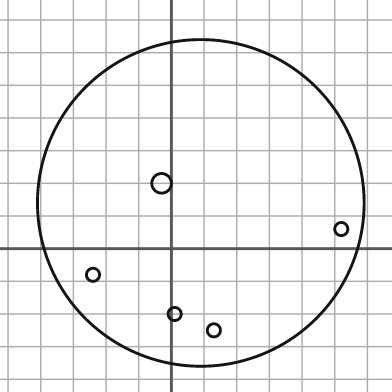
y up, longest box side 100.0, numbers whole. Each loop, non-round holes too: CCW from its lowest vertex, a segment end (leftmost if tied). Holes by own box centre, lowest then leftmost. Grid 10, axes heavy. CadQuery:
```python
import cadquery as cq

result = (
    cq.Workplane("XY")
    .moveTo(9.0, 14.0)
    .circle(50.0)
    .moveTo(13.0, -25.0)
    .circle(2.0)
    .moveTo(1.0, -20.0)
    .circle(2.0)
    .moveTo(-24.0, -8.0)
    .circle(2.0)
    .moveTo(52.0, 6.0)
    .circle(2.0)
    .moveTo(-3.0, 20.0)
    .circle(3.0)
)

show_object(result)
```